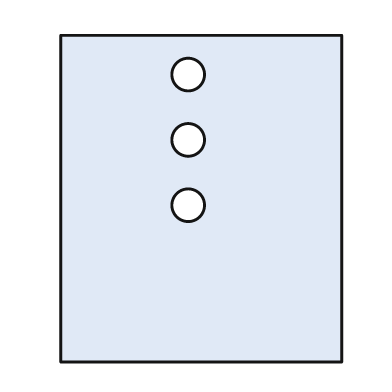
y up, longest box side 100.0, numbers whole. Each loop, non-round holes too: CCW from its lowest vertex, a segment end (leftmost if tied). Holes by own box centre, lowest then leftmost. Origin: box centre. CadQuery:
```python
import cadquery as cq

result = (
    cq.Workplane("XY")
    .moveTo(-43.0, -50.0)
    .lineTo(43.0, -50.0)
    .lineTo(43.0, 50.0)
    .lineTo(-43.0, 50.0)
    .close()
    .moveTo(-4.0, -2.0)
    .circle(5.0)
    .moveTo(-4.0, 18.0)
    .circle(5.0)
    .moveTo(-4.0, 38.0)
    .circle(5.0)
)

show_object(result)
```